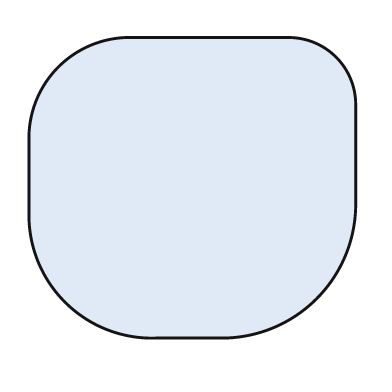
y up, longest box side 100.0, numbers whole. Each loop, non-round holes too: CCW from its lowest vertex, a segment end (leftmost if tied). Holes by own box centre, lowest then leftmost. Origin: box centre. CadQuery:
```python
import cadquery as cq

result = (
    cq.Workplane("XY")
    .moveTo(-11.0, -46.0)
    .lineTo(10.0, -46.0)
    .threePointArc((38.0, -34.0), (50.0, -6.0))
    .lineTo(50.0, 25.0)
    .threePointArc((44.0, 40.0), (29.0, 46.0))
    .lineTo(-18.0, 46.0)
    .threePointArc((-41.0, 37.0), (-50.0, 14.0))
    .lineTo(-50.0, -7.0)
    .threePointArc((-39.0, -35.0), (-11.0, -46.0))
    .close()
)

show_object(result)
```